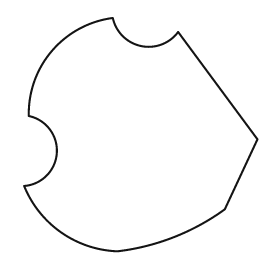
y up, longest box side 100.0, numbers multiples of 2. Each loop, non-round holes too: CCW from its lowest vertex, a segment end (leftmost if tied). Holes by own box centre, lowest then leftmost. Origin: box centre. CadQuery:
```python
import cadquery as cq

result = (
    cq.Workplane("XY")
    .moveTo(-10.0, -50.0)
    .threePointArc((14.0, -44.0), (36.0, -32.0))
    .lineTo(50.0, -2.0)
    .lineTo(16.0, 44.0)
    .threePointArc((0.0, 38.0), (-12.0, 50.0))
    .threePointArc((-38.0, 36.0), (-48.0, 8.0))
    .threePointArc((-36.0, -8.0), (-50.0, -22.0))
    .threePointArc((-34.0, -42.0), (-10.0, -50.0))
    .close()
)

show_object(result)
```